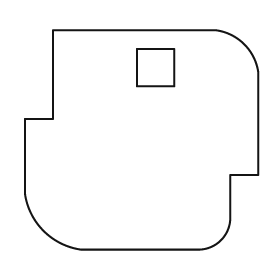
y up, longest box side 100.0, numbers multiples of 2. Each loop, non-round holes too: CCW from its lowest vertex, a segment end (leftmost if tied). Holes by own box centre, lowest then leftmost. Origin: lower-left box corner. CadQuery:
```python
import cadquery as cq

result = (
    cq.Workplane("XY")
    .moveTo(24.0, 0.0)
    .lineTo(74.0, 0.0)
    .threePointArc((84.0, 4.0), (88.0, 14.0))
    .lineTo(88.0, 32.0)
    .lineTo(100.0, 32.0)
    .lineTo(100.0, 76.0)
    .threePointArc((94.0, 88.0), (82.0, 94.0))
    .lineTo(12.0, 94.0)
    .lineTo(12.0, 56.0)
    .lineTo(0.0, 56.0)
    .lineTo(0.0, 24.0)
    .threePointArc((8.0, 8.0), (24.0, 0.0))
    .close()
    .moveTo(48.0, 70.0)
    .lineTo(64.0, 70.0)
    .lineTo(64.0, 86.0)
    .lineTo(48.0, 86.0)
    .close()
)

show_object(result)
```